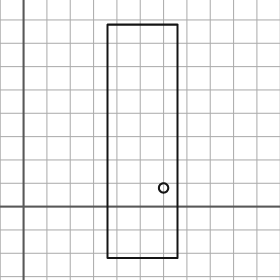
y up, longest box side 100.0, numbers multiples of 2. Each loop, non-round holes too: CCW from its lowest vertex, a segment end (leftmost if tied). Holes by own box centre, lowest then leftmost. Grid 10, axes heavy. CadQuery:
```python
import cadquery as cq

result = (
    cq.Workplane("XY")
    .moveTo(36.0, -22.0)
    .lineTo(66.0, -22.0)
    .lineTo(66.0, 78.0)
    .lineTo(36.0, 78.0)
    .close()
    .moveTo(60.0, 8.0)
    .circle(2.0)
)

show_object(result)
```